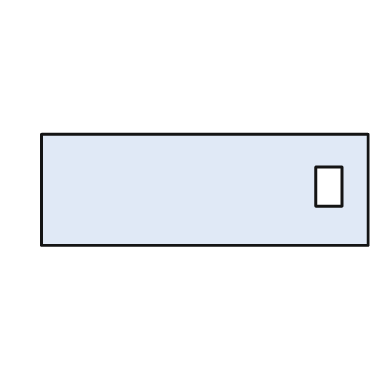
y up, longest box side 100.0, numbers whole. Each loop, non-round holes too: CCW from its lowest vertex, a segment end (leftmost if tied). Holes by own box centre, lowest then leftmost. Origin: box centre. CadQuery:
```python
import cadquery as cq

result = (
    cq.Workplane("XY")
    .moveTo(-50.0, -17.0)
    .lineTo(50.0, -17.0)
    .lineTo(50.0, 17.0)
    .lineTo(-50.0, 17.0)
    .close()
    .moveTo(34.0, -5.0)
    .lineTo(42.0, -5.0)
    .lineTo(42.0, 7.0)
    .lineTo(34.0, 7.0)
    .close()
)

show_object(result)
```